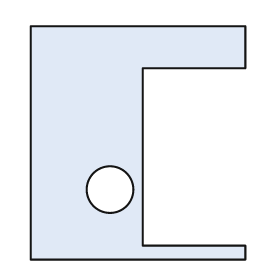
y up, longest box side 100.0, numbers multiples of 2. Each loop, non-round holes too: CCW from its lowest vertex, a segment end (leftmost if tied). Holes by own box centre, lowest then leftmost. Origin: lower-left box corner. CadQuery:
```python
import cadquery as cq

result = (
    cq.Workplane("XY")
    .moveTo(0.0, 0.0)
    .lineTo(92.0, 0.0)
    .lineTo(92.0, 6.0)
    .lineTo(48.0, 6.0)
    .lineTo(48.0, 82.0)
    .lineTo(92.0, 82.0)
    .lineTo(92.0, 100.0)
    .lineTo(0.0, 100.0)
    .close()
    .moveTo(34.0, 30.0)
    .circle(10.0)
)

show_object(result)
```